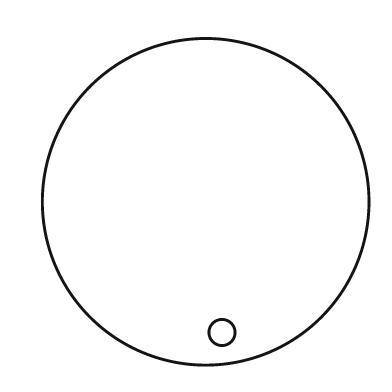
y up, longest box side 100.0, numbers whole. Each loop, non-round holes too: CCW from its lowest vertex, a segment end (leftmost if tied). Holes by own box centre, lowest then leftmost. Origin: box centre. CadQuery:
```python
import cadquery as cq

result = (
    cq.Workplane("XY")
    .moveTo(0.0, 0.0)
    .circle(50.0)
    .moveTo(5.0, -40.0)
    .circle(4.0)
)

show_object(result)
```